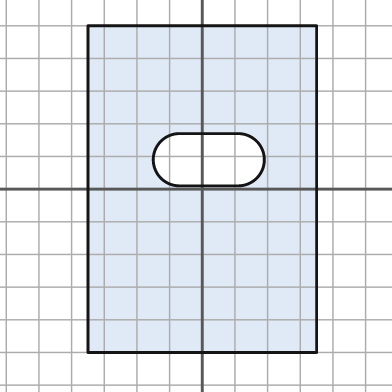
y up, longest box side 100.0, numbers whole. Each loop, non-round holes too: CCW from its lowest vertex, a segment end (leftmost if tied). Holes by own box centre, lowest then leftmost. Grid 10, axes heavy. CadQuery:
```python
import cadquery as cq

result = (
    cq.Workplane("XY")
    .moveTo(-35.0, -50.0)
    .lineTo(35.0, -50.0)
    .lineTo(35.0, 50.0)
    .lineTo(-35.0, 50.0)
    .close()
    .moveTo(-7.0, 1.0)
    .lineTo(11.0, 1.0)
    .threePointArc((19.0, 9.0), (11.0, 17.0))
    .lineTo(-7.0, 17.0)
    .threePointArc((-15.0, 9.0), (-7.0, 1.0))
    .close()
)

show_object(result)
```